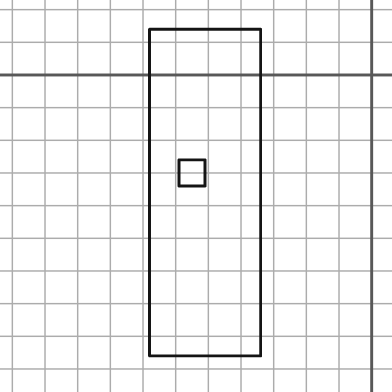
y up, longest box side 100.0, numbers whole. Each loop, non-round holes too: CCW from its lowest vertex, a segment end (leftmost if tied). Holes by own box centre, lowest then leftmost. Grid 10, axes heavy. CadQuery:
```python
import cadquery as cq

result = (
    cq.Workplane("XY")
    .moveTo(-68.0, -86.0)
    .lineTo(-34.0, -86.0)
    .lineTo(-34.0, 14.0)
    .lineTo(-68.0, 14.0)
    .close()
    .moveTo(-59.0, -34.0)
    .lineTo(-51.0, -34.0)
    .lineTo(-51.0, -26.0)
    .lineTo(-59.0, -26.0)
    .close()
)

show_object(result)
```